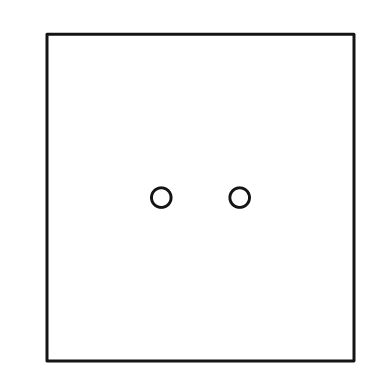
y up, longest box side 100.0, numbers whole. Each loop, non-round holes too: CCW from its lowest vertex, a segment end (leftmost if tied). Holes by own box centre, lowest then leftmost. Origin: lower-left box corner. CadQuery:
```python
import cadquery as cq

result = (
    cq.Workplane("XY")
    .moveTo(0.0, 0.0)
    .lineTo(94.0, 0.0)
    .lineTo(94.0, 100.0)
    .lineTo(0.0, 100.0)
    .close()
    .moveTo(35.0, 50.0)
    .circle(3.0)
    .moveTo(59.0, 50.0)
    .circle(3.0)
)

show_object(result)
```